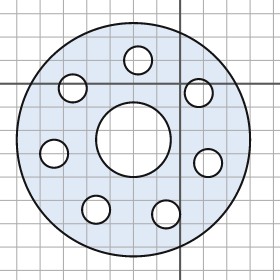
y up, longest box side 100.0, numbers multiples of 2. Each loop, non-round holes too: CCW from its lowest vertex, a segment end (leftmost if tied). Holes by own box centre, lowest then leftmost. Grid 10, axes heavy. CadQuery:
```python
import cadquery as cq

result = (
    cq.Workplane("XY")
    .moveTo(-20.0, -24.0)
    .circle(50.0)
    .moveTo(-6.0, -56.0)
    .circle(6.0)
    .moveTo(-36.0, -54.0)
    .circle(6.0)
    .moveTo(12.0, -34.0)
    .circle(6.0)
    .moveTo(-54.0, -30.0)
    .circle(6.0)
    .moveTo(-20.0, -24.0)
    .circle(16.0)
    .moveTo(8.0, -4.0)
    .circle(6.0)
    .moveTo(-46.0, -2.0)
    .circle(6.0)
    .moveTo(-18.0, 10.0)
    .circle(6.0)
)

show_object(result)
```